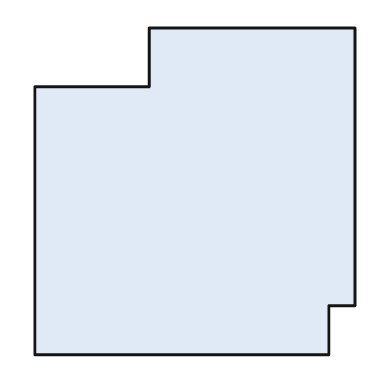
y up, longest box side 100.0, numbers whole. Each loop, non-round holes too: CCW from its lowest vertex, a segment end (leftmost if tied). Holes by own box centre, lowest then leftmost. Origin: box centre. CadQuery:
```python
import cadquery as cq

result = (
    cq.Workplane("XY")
    .moveTo(-49.0, -50.0)
    .lineTo(41.0, -50.0)
    .lineTo(41.0, -35.0)
    .lineTo(49.0, -35.0)
    .lineTo(49.0, 50.0)
    .lineTo(-14.0, 50.0)
    .lineTo(-14.0, 32.0)
    .lineTo(-49.0, 32.0)
    .close()
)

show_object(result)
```